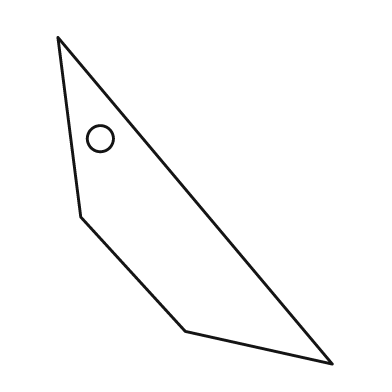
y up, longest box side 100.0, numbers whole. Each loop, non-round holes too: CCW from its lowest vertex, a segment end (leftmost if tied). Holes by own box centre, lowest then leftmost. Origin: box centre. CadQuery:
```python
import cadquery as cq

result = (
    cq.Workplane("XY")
    .moveTo(42.0, -50.0)
    .lineTo(-42.0, 50.0)
    .lineTo(-35.0, -5.0)
    .lineTo(-3.0, -40.0)
    .close()
    .moveTo(-29.0, 19.0)
    .circle(4.0)
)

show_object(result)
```